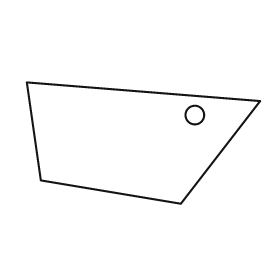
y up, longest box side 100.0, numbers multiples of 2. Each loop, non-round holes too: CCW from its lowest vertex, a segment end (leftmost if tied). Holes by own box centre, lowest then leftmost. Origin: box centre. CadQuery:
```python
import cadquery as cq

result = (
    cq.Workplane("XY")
    .moveTo(16.0, -26.0)
    .lineTo(50.0, 18.0)
    .lineTo(-50.0, 26.0)
    .lineTo(-44.0, -16.0)
    .close()
    .moveTo(22.0, 12.0)
    .circle(4.0)
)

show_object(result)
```